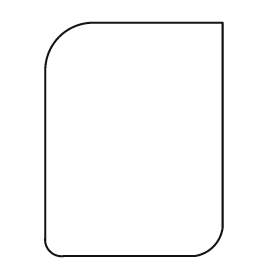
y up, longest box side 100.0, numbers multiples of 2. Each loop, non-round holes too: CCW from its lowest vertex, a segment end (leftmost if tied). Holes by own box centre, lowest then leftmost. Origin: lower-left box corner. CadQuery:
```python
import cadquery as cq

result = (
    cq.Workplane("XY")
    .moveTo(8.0, 0.0)
    .lineTo(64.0, 0.0)
    .threePointArc((72.0, 4.0), (76.0, 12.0))
    .lineTo(76.0, 100.0)
    .lineTo(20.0, 100.0)
    .threePointArc((6.0, 94.0), (0.0, 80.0))
    .lineTo(0.0, 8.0)
    .threePointArc((2.0, 2.0), (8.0, 0.0))
    .close()
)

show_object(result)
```